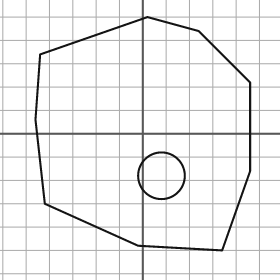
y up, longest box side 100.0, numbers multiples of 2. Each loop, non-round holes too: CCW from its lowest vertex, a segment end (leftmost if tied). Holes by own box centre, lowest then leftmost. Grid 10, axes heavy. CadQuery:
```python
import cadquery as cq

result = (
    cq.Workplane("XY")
    .moveTo(34.0, -50.0)
    .lineTo(46.0, -16.0)
    .lineTo(46.0, 22.0)
    .lineTo(24.0, 44.0)
    .lineTo(2.0, 50.0)
    .lineTo(-44.0, 34.0)
    .lineTo(-46.0, 6.0)
    .lineTo(-42.0, -30.0)
    .lineTo(-2.0, -48.0)
    .close()
    .moveTo(8.0, -18.0)
    .circle(10.0)
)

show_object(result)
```